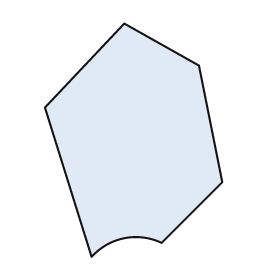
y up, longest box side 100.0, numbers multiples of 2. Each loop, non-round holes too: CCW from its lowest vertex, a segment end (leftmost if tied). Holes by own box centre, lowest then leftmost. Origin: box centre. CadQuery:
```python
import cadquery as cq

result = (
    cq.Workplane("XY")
    .moveTo(-18.0, -50.0)
    .threePointArc((-4.0, -42.0), (12.0, -44.0))
    .lineTo(38.0, -18.0)
    .lineTo(28.0, 32.0)
    .lineTo(-4.0, 50.0)
    .lineTo(-38.0, 14.0)
    .close()
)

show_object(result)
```